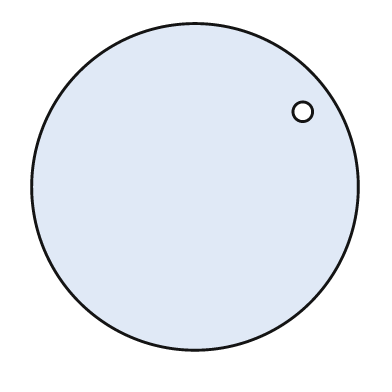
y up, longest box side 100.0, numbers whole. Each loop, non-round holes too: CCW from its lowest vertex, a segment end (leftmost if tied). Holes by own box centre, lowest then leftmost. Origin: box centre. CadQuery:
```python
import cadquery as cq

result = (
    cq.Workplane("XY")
    .moveTo(0.0, 0.0)
    .circle(50.0)
    .moveTo(33.0, 23.0)
    .circle(3.0)
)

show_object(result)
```